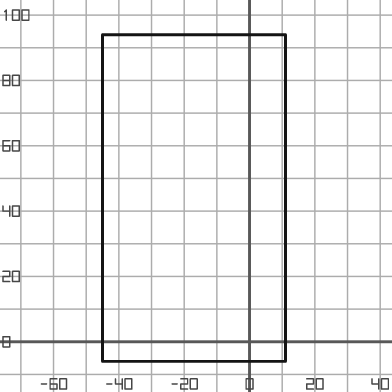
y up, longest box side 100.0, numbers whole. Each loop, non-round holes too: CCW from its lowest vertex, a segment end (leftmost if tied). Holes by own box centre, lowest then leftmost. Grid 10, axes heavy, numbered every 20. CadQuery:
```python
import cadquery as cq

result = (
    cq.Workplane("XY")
    .moveTo(-45.0, -6.0)
    .lineTo(11.0, -6.0)
    .lineTo(11.0, 94.0)
    .lineTo(-45.0, 94.0)
    .close()
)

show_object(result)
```